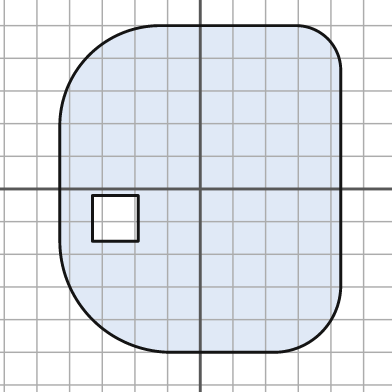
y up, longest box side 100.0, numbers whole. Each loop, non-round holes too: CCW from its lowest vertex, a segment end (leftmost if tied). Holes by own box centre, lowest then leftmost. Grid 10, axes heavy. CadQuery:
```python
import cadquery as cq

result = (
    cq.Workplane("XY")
    .moveTo(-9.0, -50.0)
    .lineTo(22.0, -50.0)
    .threePointArc((37.0, -44.0), (43.0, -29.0))
    .lineTo(43.0, 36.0)
    .threePointArc((39.0, 46.0), (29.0, 50.0))
    .lineTo(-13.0, 50.0)
    .threePointArc((-34.0, 41.0), (-43.0, 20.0))
    .lineTo(-43.0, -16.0)
    .threePointArc((-33.0, -40.0), (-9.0, -50.0))
    .close()
    .moveTo(-33.0, -16.0)
    .lineTo(-19.0, -16.0)
    .lineTo(-19.0, -2.0)
    .lineTo(-33.0, -2.0)
    .close()
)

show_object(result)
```